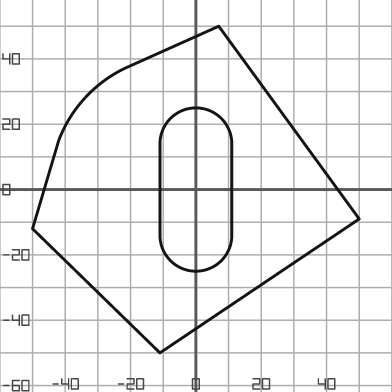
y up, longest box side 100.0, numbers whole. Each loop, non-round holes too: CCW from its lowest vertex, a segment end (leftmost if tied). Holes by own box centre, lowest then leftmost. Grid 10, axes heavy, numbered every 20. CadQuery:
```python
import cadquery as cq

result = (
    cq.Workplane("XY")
    .moveTo(-11.0, -50.0)
    .lineTo(50.0, -9.0)
    .lineTo(7.0, 50.0)
    .lineTo(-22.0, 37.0)
    .threePointArc((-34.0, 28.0), (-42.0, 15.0))
    .lineTo(-50.0, -12.0)
    .close()
    .moveTo(-11.0, -14.0)
    .threePointArc((0.0, -25.0), (11.0, -14.0))
    .lineTo(11.0, 14.0)
    .threePointArc((0.0, 25.0), (-11.0, 14.0))
    .close()
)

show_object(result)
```